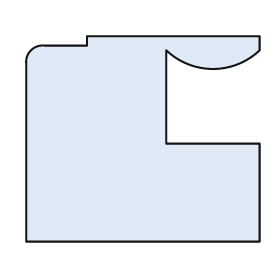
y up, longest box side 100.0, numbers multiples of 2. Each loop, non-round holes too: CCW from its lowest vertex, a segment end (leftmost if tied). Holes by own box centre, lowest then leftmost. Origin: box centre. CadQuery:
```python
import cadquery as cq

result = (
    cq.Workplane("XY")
    .moveTo(-50.0, -44.0)
    .lineTo(50.0, -44.0)
    .lineTo(50.0, -2.0)
    .lineTo(10.0, -2.0)
    .lineTo(10.0, 38.0)
    .threePointArc((30.0, 30.0), (50.0, 38.0))
    .lineTo(50.0, 44.0)
    .lineTo(-24.0, 44.0)
    .lineTo(-24.0, 40.0)
    .lineTo(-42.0, 40.0)
    .threePointArc((-48.0, 38.0), (-50.0, 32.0))
    .close()
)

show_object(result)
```